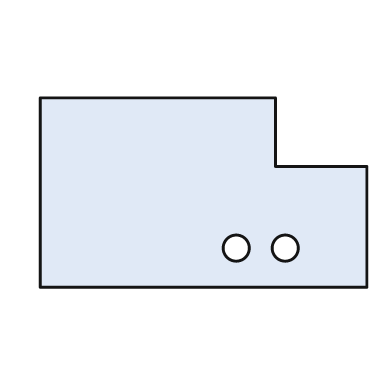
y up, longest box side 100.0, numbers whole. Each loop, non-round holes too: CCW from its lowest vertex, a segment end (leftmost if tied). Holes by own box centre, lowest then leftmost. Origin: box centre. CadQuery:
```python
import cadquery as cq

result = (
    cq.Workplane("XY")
    .moveTo(-50.0, -29.0)
    .lineTo(50.0, -29.0)
    .lineTo(50.0, 8.0)
    .lineTo(22.0, 8.0)
    .lineTo(22.0, 29.0)
    .lineTo(-50.0, 29.0)
    .close()
    .moveTo(10.0, -17.0)
    .circle(4.0)
    .moveTo(25.0, -17.0)
    .circle(4.0)
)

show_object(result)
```